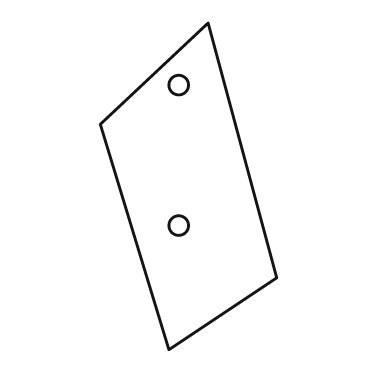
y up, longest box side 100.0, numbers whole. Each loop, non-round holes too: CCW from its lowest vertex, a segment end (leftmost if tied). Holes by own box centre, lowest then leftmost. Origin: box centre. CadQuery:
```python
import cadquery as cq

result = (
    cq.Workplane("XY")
    .moveTo(-6.0, -50.0)
    .lineTo(27.0, -28.0)
    .lineTo(6.0, 50.0)
    .lineTo(-27.0, 19.0)
    .close()
    .moveTo(-3.0, -12.0)
    .circle(3.0)
    .moveTo(-3.0, 31.0)
    .circle(3.0)
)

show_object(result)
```